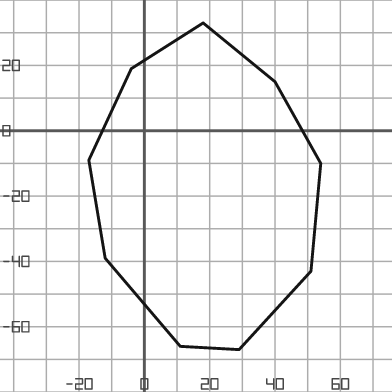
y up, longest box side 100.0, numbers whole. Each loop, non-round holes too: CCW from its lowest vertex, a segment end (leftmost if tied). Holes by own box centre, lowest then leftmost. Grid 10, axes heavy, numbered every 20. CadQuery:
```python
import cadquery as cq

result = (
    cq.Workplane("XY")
    .moveTo(29.0, -67.0)
    .lineTo(51.0, -43.0)
    .lineTo(54.0, -10.0)
    .lineTo(40.0, 15.0)
    .lineTo(18.0, 33.0)
    .lineTo(-4.0, 19.0)
    .lineTo(-17.0, -9.0)
    .lineTo(-12.0, -39.0)
    .lineTo(11.0, -66.0)
    .close()
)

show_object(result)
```